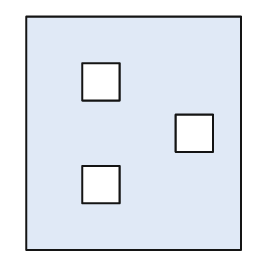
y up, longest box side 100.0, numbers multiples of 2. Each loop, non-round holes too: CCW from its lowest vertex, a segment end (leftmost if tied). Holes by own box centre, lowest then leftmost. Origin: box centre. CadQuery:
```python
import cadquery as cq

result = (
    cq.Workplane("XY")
    .moveTo(-46.0, -50.0)
    .lineTo(46.0, -50.0)
    .lineTo(46.0, 50.0)
    .lineTo(-46.0, 50.0)
    .close()
    .moveTo(-22.0, -30.0)
    .lineTo(-6.0, -30.0)
    .lineTo(-6.0, -14.0)
    .lineTo(-22.0, -14.0)
    .close()
    .moveTo(18.0, -8.0)
    .lineTo(34.0, -8.0)
    .lineTo(34.0, 8.0)
    .lineTo(18.0, 8.0)
    .close()
    .moveTo(-22.0, 14.0)
    .lineTo(-6.0, 14.0)
    .lineTo(-6.0, 30.0)
    .lineTo(-22.0, 30.0)
    .close()
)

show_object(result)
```